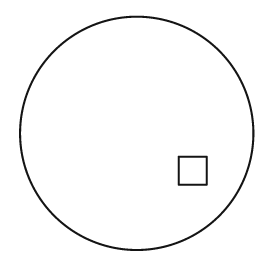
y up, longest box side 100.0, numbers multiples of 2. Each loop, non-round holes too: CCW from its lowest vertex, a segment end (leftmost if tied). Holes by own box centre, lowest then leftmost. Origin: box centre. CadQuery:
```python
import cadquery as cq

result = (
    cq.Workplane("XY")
    .moveTo(0.0, 0.0)
    .circle(50.0)
    .moveTo(18.0, -22.0)
    .lineTo(30.0, -22.0)
    .lineTo(30.0, -10.0)
    .lineTo(18.0, -10.0)
    .close()
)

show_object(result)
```